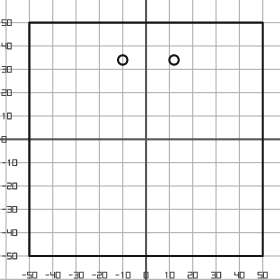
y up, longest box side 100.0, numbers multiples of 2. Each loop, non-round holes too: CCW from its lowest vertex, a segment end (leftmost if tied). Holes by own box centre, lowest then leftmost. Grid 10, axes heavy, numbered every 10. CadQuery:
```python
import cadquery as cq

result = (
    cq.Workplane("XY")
    .moveTo(-50.0, -50.0)
    .lineTo(50.0, -50.0)
    .lineTo(50.0, 50.0)
    .lineTo(-50.0, 50.0)
    .close()
    .moveTo(-10.0, 34.0)
    .circle(2.0)
    .moveTo(12.0, 34.0)
    .circle(2.0)
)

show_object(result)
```